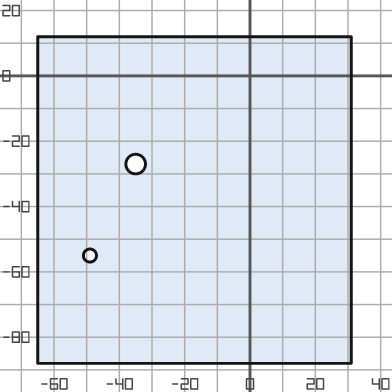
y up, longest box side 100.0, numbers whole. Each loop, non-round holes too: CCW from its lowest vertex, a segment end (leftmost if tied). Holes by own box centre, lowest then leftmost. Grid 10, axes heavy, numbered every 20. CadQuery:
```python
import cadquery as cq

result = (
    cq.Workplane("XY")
    .moveTo(-65.0, -88.0)
    .lineTo(31.0, -88.0)
    .lineTo(31.0, 12.0)
    .lineTo(-65.0, 12.0)
    .close()
    .moveTo(-49.0, -55.0)
    .circle(2.0)
    .moveTo(-35.0, -27.0)
    .circle(3.0)
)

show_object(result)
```